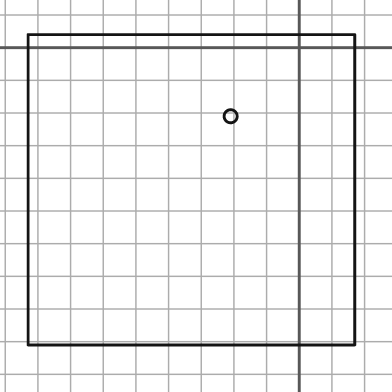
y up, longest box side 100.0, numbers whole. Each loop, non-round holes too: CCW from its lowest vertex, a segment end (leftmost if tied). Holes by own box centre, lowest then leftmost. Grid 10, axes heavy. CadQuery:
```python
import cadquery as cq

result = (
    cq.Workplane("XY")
    .moveTo(-83.0, -91.0)
    .lineTo(17.0, -91.0)
    .lineTo(17.0, 4.0)
    .lineTo(-83.0, 4.0)
    .close()
    .moveTo(-21.0, -21.0)
    .circle(2.0)
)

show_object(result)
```